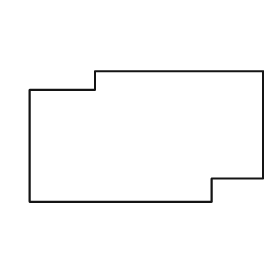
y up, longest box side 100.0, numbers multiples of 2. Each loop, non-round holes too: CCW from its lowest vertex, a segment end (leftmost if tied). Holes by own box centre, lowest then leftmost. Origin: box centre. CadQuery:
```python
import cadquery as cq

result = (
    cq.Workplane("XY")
    .moveTo(-50.0, -28.0)
    .lineTo(28.0, -28.0)
    .lineTo(28.0, -18.0)
    .lineTo(50.0, -18.0)
    .lineTo(50.0, 28.0)
    .lineTo(-22.0, 28.0)
    .lineTo(-22.0, 20.0)
    .lineTo(-50.0, 20.0)
    .close()
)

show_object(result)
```